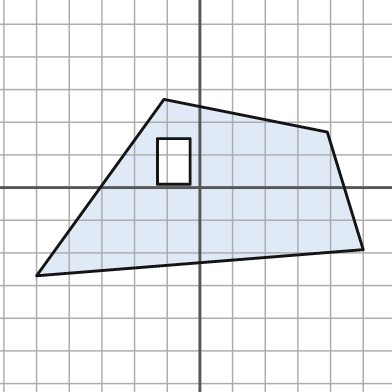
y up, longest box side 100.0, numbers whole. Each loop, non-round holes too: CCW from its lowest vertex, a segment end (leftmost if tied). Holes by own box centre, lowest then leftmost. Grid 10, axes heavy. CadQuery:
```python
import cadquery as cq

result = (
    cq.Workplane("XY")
    .moveTo(-50.0, -27.0)
    .lineTo(50.0, -19.0)
    .lineTo(39.0, 17.0)
    .lineTo(-11.0, 27.0)
    .close()
    .moveTo(-13.0, 1.0)
    .lineTo(-3.0, 1.0)
    .lineTo(-3.0, 15.0)
    .lineTo(-13.0, 15.0)
    .close()
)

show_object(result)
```